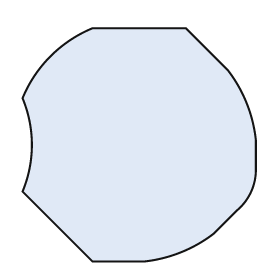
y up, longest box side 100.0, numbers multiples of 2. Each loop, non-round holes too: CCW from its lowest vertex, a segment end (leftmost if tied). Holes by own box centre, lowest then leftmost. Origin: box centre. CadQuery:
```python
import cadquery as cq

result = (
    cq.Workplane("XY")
    .moveTo(-20.0, -50.0)
    .lineTo(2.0, -50.0)
    .threePointArc((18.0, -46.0), (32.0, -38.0))
    .lineTo(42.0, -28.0)
    .threePointArc((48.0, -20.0), (50.0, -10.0))
    .lineTo(50.0, 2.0)
    .threePointArc((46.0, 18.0), (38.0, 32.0))
    .lineTo(20.0, 50.0)
    .lineTo(-20.0, 50.0)
    .threePointArc((-38.0, 38.0), (-50.0, 20.0))
    .threePointArc((-46.0, 0.0), (-50.0, -20.0))
    .close()
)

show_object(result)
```